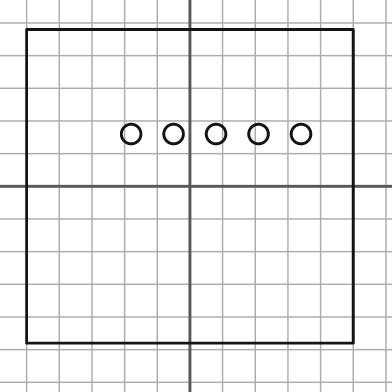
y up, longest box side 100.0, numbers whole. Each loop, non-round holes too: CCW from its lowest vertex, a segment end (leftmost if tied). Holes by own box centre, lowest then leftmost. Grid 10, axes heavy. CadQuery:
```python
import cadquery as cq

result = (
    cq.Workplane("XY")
    .moveTo(-50.0, -48.0)
    .lineTo(50.0, -48.0)
    .lineTo(50.0, 48.0)
    .lineTo(-50.0, 48.0)
    .close()
    .moveTo(-18.0, 16.0)
    .circle(3.0)
    .moveTo(-5.0, 16.0)
    .circle(3.0)
    .moveTo(8.0, 16.0)
    .circle(3.0)
    .moveTo(21.0, 16.0)
    .circle(3.0)
    .moveTo(34.0, 16.0)
    .circle(3.0)
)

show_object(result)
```